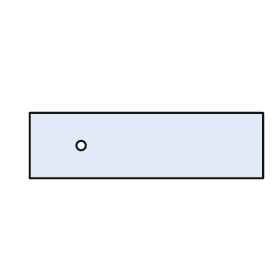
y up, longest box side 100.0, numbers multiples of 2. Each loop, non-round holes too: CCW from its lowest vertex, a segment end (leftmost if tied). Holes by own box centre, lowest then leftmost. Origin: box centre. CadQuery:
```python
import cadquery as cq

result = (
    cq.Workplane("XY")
    .moveTo(-50.0, -14.0)
    .lineTo(50.0, -14.0)
    .lineTo(50.0, 14.0)
    .lineTo(-50.0, 14.0)
    .close()
    .moveTo(-28.0, 0.0)
    .circle(2.0)
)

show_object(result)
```